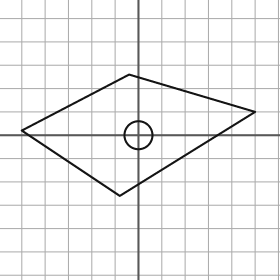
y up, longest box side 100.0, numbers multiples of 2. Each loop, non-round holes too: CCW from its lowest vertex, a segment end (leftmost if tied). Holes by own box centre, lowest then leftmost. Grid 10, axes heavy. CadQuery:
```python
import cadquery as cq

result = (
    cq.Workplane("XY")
    .moveTo(-8.0, -26.0)
    .lineTo(50.0, 10.0)
    .lineTo(-4.0, 26.0)
    .lineTo(-50.0, 2.0)
    .close()
    .moveTo(0.0, 0.0)
    .circle(6.0)
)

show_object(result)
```